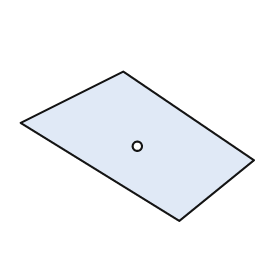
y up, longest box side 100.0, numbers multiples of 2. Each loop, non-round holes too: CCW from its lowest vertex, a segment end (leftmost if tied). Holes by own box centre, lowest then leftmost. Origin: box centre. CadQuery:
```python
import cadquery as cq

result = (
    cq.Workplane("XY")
    .moveTo(18.0, -32.0)
    .lineTo(50.0, -6.0)
    .lineTo(-6.0, 32.0)
    .lineTo(-50.0, 10.0)
    .close()
    .moveTo(0.0, 0.0)
    .circle(2.0)
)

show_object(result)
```